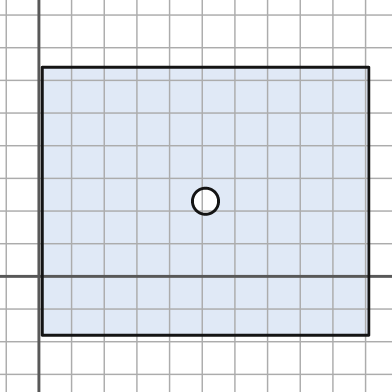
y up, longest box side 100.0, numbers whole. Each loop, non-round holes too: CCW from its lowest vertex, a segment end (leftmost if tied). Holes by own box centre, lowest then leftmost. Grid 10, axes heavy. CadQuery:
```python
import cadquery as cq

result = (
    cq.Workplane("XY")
    .moveTo(1.0, -18.0)
    .lineTo(101.0, -18.0)
    .lineTo(101.0, 64.0)
    .lineTo(1.0, 64.0)
    .close()
    .moveTo(51.0, 23.0)
    .circle(4.0)
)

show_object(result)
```